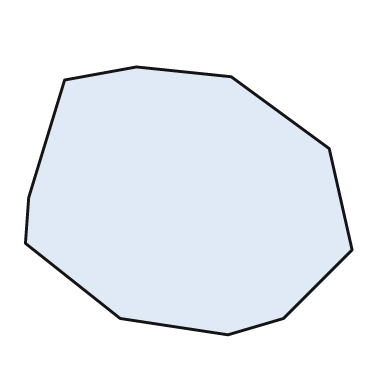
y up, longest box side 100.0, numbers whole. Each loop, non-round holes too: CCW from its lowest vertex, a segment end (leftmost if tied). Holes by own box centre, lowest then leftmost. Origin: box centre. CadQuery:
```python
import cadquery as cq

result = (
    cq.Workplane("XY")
    .moveTo(12.0, -41.0)
    .lineTo(29.0, -36.0)
    .lineTo(50.0, -15.0)
    .lineTo(43.0, 16.0)
    .lineTo(13.0, 38.0)
    .lineTo(-16.0, 41.0)
    .lineTo(-38.0, 37.0)
    .lineTo(-49.0, 1.0)
    .lineTo(-50.0, -13.0)
    .lineTo(-21.0, -36.0)
    .close()
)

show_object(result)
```